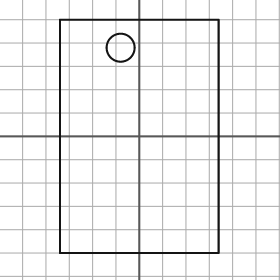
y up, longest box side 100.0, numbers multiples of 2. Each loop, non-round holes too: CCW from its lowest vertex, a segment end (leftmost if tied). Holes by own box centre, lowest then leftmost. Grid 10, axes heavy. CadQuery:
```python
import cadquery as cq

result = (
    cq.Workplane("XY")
    .moveTo(-34.0, -50.0)
    .lineTo(34.0, -50.0)
    .lineTo(34.0, 50.0)
    .lineTo(-34.0, 50.0)
    .close()
    .moveTo(-8.0, 38.0)
    .circle(6.0)
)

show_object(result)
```